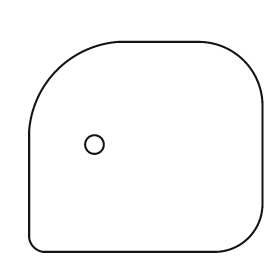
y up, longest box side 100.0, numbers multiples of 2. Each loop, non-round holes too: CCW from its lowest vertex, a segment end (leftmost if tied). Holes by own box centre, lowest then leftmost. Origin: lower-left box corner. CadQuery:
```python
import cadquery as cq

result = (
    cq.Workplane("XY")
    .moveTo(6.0, 0.0)
    .lineTo(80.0, 0.0)
    .threePointArc((94.0, 6.0), (100.0, 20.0))
    .lineTo(100.0, 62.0)
    .threePointArc((92.0, 82.0), (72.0, 90.0))
    .lineTo(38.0, 90.0)
    .threePointArc((12.0, 78.0), (0.0, 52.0))
    .lineTo(0.0, 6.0)
    .threePointArc((2.0, 2.0), (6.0, 0.0))
    .close()
    .moveTo(28.0, 46.0)
    .circle(4.0)
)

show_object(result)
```